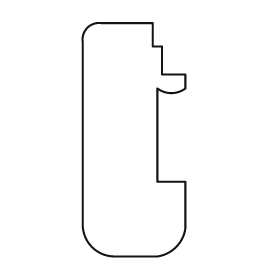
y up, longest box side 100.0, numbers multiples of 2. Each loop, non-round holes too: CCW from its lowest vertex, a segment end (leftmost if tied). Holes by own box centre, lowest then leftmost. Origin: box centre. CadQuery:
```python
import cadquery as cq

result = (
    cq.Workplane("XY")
    .moveTo(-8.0, -50.0)
    .lineTo(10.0, -50.0)
    .threePointArc((18.0, -46.0), (22.0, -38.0))
    .lineTo(22.0, -18.0)
    .lineTo(10.0, -18.0)
    .lineTo(10.0, 22.0)
    .threePointArc((16.0, 20.0), (22.0, 22.0))
    .lineTo(22.0, 28.0)
    .lineTo(12.0, 28.0)
    .lineTo(12.0, 40.0)
    .lineTo(8.0, 40.0)
    .lineTo(8.0, 50.0)
    .lineTo(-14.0, 50.0)
    .threePointArc((-20.0, 48.0), (-22.0, 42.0))
    .lineTo(-22.0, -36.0)
    .threePointArc((-18.0, -46.0), (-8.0, -50.0))
    .close()
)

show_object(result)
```